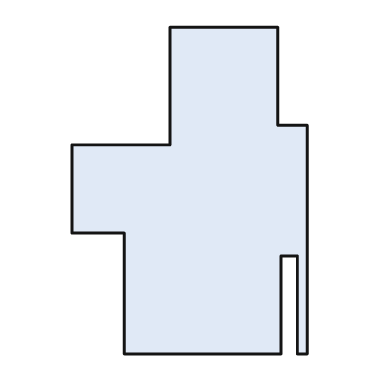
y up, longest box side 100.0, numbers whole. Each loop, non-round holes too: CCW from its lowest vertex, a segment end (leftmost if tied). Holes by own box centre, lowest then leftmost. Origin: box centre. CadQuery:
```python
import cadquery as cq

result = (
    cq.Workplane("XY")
    .moveTo(-20.0, -50.0)
    .lineTo(28.0, -50.0)
    .lineTo(28.0, -20.0)
    .lineTo(33.0, -20.0)
    .lineTo(33.0, -50.0)
    .lineTo(36.0, -50.0)
    .lineTo(36.0, 20.0)
    .lineTo(27.0, 20.0)
    .lineTo(27.0, 50.0)
    .lineTo(-6.0, 50.0)
    .lineTo(-6.0, 14.0)
    .lineTo(-36.0, 14.0)
    .lineTo(-36.0, -13.0)
    .lineTo(-20.0, -13.0)
    .close()
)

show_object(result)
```